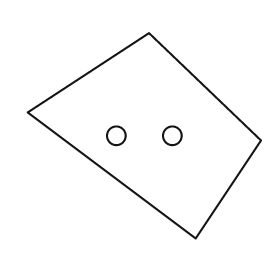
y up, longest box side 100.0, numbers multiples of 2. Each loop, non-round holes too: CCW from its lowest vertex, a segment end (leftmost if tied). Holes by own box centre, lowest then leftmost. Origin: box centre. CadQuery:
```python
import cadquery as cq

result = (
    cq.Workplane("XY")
    .moveTo(22.0, -44.0)
    .lineTo(50.0, -2.0)
    .lineTo(2.0, 44.0)
    .lineTo(-50.0, 10.0)
    .close()
    .moveTo(-12.0, 0.0)
    .circle(4.0)
    .moveTo(12.0, 0.0)
    .circle(4.0)
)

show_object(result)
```